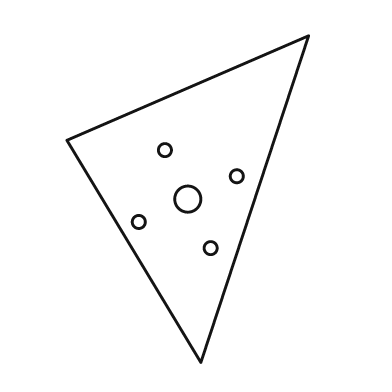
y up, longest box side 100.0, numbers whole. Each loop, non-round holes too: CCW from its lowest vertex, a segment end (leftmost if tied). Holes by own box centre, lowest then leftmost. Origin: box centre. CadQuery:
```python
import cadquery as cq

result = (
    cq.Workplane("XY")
    .moveTo(4.0, -50.0)
    .lineTo(37.0, 50.0)
    .lineTo(-37.0, 18.0)
    .close()
    .moveTo(7.0, -15.0)
    .circle(2.0)
    .moveTo(-15.0, -7.0)
    .circle(2.0)
    .moveTo(0.0, 0.0)
    .circle(4.0)
    .moveTo(15.0, 7.0)
    .circle(2.0)
    .moveTo(-7.0, 15.0)
    .circle(2.0)
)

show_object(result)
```